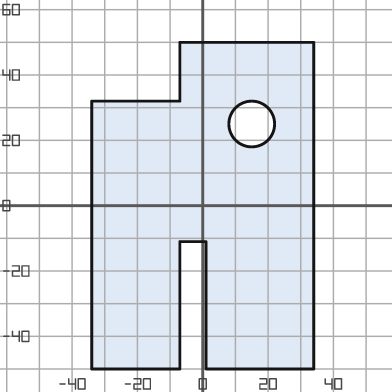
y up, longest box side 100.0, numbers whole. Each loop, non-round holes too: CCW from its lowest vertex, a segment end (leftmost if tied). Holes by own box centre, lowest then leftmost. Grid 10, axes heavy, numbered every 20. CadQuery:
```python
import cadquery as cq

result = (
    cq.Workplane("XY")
    .moveTo(-34.0, -50.0)
    .lineTo(-7.0, -50.0)
    .lineTo(-7.0, -11.0)
    .lineTo(1.0, -11.0)
    .lineTo(1.0, -50.0)
    .lineTo(34.0, -50.0)
    .lineTo(34.0, 50.0)
    .lineTo(-7.0, 50.0)
    .lineTo(-7.0, 32.0)
    .lineTo(-34.0, 32.0)
    .close()
    .moveTo(15.0, 25.0)
    .circle(7.0)
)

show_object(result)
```